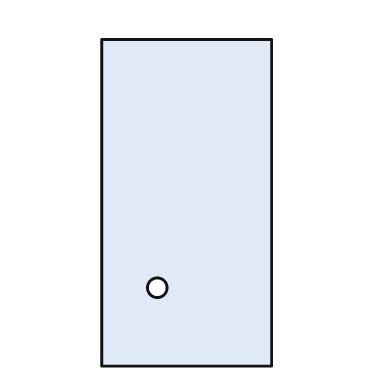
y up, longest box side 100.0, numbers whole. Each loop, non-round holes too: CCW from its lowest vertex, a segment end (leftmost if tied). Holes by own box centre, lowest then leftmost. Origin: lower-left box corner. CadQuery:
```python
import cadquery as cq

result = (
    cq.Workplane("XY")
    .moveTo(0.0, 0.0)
    .lineTo(52.0, 0.0)
    .lineTo(52.0, 100.0)
    .lineTo(0.0, 100.0)
    .close()
    .moveTo(17.0, 24.0)
    .circle(3.0)
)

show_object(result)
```